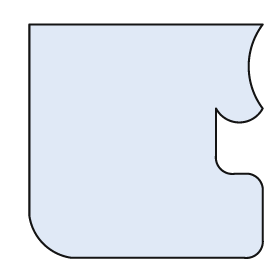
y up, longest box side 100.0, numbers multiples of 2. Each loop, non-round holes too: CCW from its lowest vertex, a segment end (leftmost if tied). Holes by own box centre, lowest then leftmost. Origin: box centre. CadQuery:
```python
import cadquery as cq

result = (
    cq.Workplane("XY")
    .moveTo(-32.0, -50.0)
    .lineTo(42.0, -50.0)
    .threePointArc((48.0, -48.0), (50.0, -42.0))
    .lineTo(50.0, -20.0)
    .threePointArc((48.0, -16.0), (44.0, -14.0))
    .lineTo(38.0, -14.0)
    .threePointArc((32.0, -12.0), (30.0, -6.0))
    .lineTo(30.0, 14.0)
    .threePointArc((40.0, 8.0), (50.0, 14.0))
    .threePointArc((44.0, 32.0), (50.0, 50.0))
    .lineTo(-50.0, 50.0)
    .lineTo(-50.0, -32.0)
    .threePointArc((-44.0, -44.0), (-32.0, -50.0))
    .close()
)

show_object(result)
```